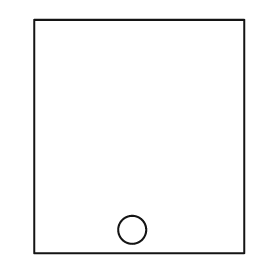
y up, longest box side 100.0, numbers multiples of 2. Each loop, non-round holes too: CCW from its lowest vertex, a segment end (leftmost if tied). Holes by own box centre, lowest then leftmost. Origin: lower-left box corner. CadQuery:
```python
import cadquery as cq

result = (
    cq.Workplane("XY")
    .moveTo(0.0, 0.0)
    .lineTo(90.0, 0.0)
    .lineTo(90.0, 100.0)
    .lineTo(0.0, 100.0)
    .close()
    .moveTo(42.0, 10.0)
    .circle(6.0)
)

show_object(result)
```